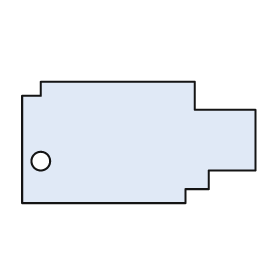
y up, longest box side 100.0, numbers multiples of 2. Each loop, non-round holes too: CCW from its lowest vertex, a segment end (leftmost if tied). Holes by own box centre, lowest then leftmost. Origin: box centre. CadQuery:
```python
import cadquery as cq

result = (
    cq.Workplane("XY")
    .moveTo(-50.0, -26.0)
    .lineTo(20.0, -26.0)
    .lineTo(20.0, -20.0)
    .lineTo(30.0, -20.0)
    .lineTo(30.0, -12.0)
    .lineTo(50.0, -12.0)
    .lineTo(50.0, 14.0)
    .lineTo(24.0, 14.0)
    .lineTo(24.0, 26.0)
    .lineTo(-42.0, 26.0)
    .lineTo(-42.0, 20.0)
    .lineTo(-50.0, 20.0)
    .close()
    .moveTo(-42.0, -8.0)
    .circle(4.0)
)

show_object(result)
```